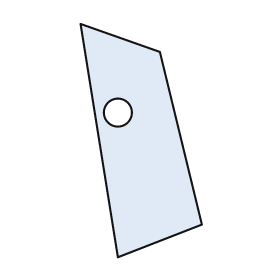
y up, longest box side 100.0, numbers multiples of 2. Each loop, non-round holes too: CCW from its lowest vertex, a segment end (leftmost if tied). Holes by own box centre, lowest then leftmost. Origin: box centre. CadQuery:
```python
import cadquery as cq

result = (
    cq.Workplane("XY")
    .moveTo(-10.0, -50.0)
    .lineTo(26.0, -36.0)
    .lineTo(8.0, 38.0)
    .lineTo(-26.0, 50.0)
    .close()
    .moveTo(-10.0, 12.0)
    .circle(6.0)
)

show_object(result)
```